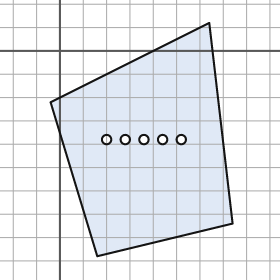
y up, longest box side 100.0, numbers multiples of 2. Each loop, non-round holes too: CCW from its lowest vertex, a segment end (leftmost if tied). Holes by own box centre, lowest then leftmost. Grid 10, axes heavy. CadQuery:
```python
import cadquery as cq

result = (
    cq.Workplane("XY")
    .moveTo(16.0, -88.0)
    .lineTo(74.0, -74.0)
    .lineTo(64.0, 12.0)
    .lineTo(-4.0, -22.0)
    .close()
    .moveTo(20.0, -38.0)
    .circle(2.0)
    .moveTo(28.0, -38.0)
    .circle(2.0)
    .moveTo(36.0, -38.0)
    .circle(2.0)
    .moveTo(44.0, -38.0)
    .circle(2.0)
    .moveTo(52.0, -38.0)
    .circle(2.0)
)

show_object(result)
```